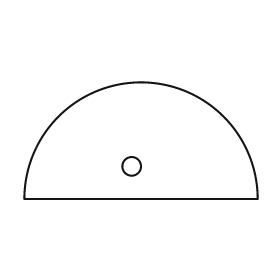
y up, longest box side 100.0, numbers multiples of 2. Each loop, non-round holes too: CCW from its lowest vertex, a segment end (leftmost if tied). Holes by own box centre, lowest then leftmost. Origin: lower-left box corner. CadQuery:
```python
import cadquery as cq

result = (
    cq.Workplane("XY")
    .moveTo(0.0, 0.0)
    .lineTo(100.0, 0.0)
    .threePointArc((50.0, 50.0), (0.0, 0.0))
    .close()
    .moveTo(46.0, 14.0)
    .circle(4.0)
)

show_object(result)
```